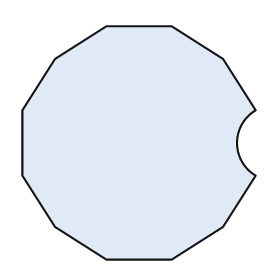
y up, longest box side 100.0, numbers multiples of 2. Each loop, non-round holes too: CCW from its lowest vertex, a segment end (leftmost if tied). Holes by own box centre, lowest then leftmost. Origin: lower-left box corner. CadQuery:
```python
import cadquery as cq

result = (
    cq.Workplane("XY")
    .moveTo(36.0, 0.0)
    .lineTo(64.0, 0.0)
    .lineTo(86.0, 14.0)
    .lineTo(100.0, 36.0)
    .threePointArc((92.0, 50.0), (100.0, 64.0))
    .lineTo(86.0, 86.0)
    .lineTo(64.0, 100.0)
    .lineTo(36.0, 100.0)
    .lineTo(14.0, 86.0)
    .lineTo(0.0, 64.0)
    .lineTo(0.0, 36.0)
    .lineTo(14.0, 14.0)
    .close()
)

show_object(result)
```